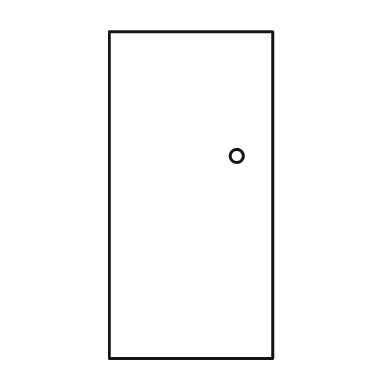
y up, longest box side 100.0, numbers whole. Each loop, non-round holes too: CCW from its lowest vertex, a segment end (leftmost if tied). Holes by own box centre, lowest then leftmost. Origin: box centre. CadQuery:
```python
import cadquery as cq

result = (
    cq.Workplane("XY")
    .moveTo(-25.0, -50.0)
    .lineTo(25.0, -50.0)
    .lineTo(25.0, 50.0)
    .lineTo(-25.0, 50.0)
    .close()
    .moveTo(14.0, 12.0)
    .circle(2.0)
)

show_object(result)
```